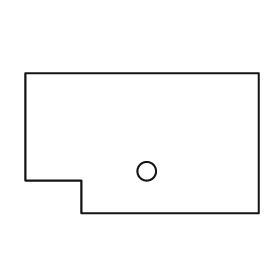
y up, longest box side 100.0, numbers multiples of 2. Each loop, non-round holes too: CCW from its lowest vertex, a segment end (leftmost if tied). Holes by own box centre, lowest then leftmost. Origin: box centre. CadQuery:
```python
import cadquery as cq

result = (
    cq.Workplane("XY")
    .moveTo(-26.0, -30.0)
    .lineTo(50.0, -30.0)
    .lineTo(50.0, 30.0)
    .lineTo(-50.0, 30.0)
    .lineTo(-50.0, -16.0)
    .lineTo(-26.0, -16.0)
    .close()
    .moveTo(2.0, -12.0)
    .circle(4.0)
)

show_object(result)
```